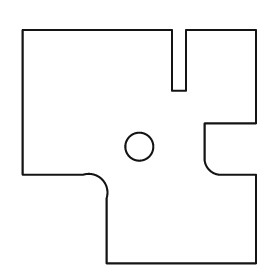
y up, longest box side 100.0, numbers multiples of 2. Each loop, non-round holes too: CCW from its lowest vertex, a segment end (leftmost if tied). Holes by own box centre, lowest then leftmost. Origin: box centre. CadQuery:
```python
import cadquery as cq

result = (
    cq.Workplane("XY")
    .moveTo(-14.0, -50.0)
    .lineTo(50.0, -50.0)
    .lineTo(50.0, -12.0)
    .lineTo(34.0, -12.0)
    .threePointArc((30.0, -10.0), (28.0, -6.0))
    .lineTo(28.0, 10.0)
    .lineTo(50.0, 10.0)
    .lineTo(50.0, 50.0)
    .lineTo(20.0, 50.0)
    .lineTo(20.0, 24.0)
    .lineTo(14.0, 24.0)
    .lineTo(14.0, 50.0)
    .lineTo(-50.0, 50.0)
    .lineTo(-50.0, -12.0)
    .lineTo(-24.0, -12.0)
    .threePointArc((-16.0, -14.0), (-14.0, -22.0))
    .close()
    .moveTo(0.0, 0.0)
    .circle(6.0)
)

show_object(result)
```